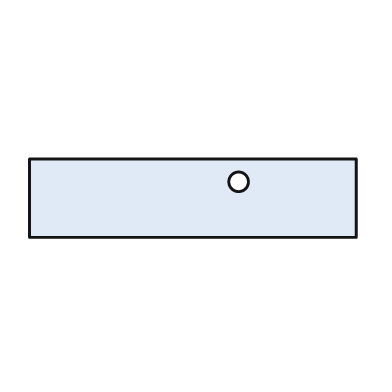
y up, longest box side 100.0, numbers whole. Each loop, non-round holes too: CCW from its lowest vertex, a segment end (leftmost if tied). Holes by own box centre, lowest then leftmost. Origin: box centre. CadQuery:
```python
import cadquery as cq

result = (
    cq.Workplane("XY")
    .moveTo(-50.0, -12.0)
    .lineTo(50.0, -12.0)
    .lineTo(50.0, 12.0)
    .lineTo(-50.0, 12.0)
    .close()
    .moveTo(14.0, 5.0)
    .circle(3.0)
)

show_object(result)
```